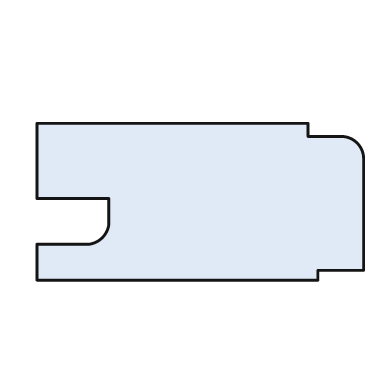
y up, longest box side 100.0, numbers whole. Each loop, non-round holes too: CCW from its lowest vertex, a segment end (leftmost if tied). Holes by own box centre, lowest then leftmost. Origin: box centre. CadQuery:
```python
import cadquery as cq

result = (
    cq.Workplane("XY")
    .moveTo(-50.0, -24.0)
    .lineTo(36.0, -24.0)
    .lineTo(36.0, -21.0)
    .lineTo(50.0, -21.0)
    .lineTo(50.0, 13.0)
    .threePointArc((48.0, 18.0), (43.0, 20.0))
    .lineTo(33.0, 20.0)
    .lineTo(33.0, 24.0)
    .lineTo(-50.0, 24.0)
    .lineTo(-50.0, 1.0)
    .lineTo(-28.0, 1.0)
    .lineTo(-28.0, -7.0)
    .threePointArc((-30.0, -11.0), (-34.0, -13.0))
    .lineTo(-50.0, -13.0)
    .close()
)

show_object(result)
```